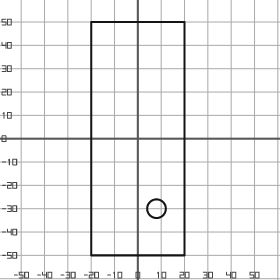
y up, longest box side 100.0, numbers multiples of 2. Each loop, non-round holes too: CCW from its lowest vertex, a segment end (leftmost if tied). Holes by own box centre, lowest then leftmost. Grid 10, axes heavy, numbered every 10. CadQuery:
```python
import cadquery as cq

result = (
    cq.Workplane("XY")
    .moveTo(-20.0, -50.0)
    .lineTo(20.0, -50.0)
    .lineTo(20.0, 50.0)
    .lineTo(-20.0, 50.0)
    .close()
    .moveTo(8.0, -30.0)
    .circle(4.0)
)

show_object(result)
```